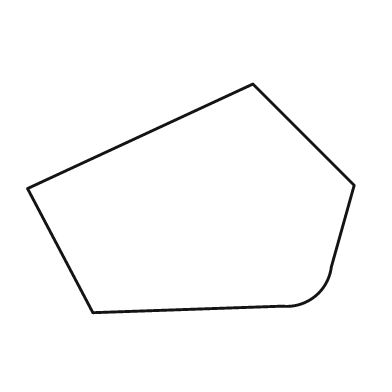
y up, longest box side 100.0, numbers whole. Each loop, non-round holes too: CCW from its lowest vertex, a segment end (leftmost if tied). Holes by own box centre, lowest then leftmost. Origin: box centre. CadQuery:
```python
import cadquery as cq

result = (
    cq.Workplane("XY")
    .moveTo(-30.0, -35.0)
    .lineTo(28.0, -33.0)
    .threePointArc((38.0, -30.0), (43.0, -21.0))
    .lineTo(50.0, 4.0)
    .lineTo(19.0, 35.0)
    .lineTo(-50.0, 3.0)
    .close()
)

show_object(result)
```